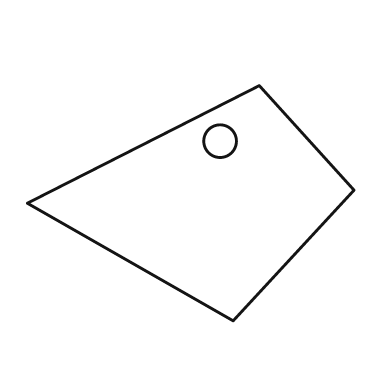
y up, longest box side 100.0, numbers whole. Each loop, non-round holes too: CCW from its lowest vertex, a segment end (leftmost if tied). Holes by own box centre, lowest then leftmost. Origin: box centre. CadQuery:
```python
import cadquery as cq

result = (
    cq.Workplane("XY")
    .moveTo(13.0, -36.0)
    .lineTo(50.0, 4.0)
    .lineTo(21.0, 36.0)
    .lineTo(-50.0, 0.0)
    .close()
    .moveTo(9.0, 19.0)
    .circle(5.0)
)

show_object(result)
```